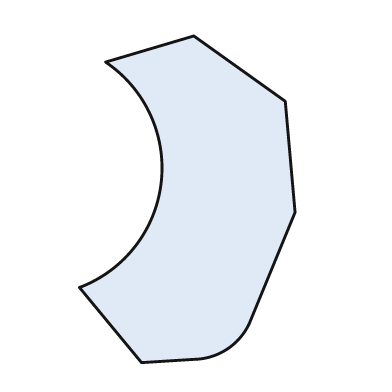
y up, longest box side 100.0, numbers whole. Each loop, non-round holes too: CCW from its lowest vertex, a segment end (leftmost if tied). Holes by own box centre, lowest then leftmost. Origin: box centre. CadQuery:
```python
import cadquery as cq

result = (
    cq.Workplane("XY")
    .moveTo(-14.0, -50.0)
    .lineTo(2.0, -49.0)
    .threePointArc((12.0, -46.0), (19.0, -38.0))
    .lineTo(33.0, -4.0)
    .lineTo(30.0, 30.0)
    .lineTo(2.0, 50.0)
    .lineTo(-25.0, 42.0)
    .threePointArc((-8.0, 5.0), (-33.0, -27.0))
    .close()
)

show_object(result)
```